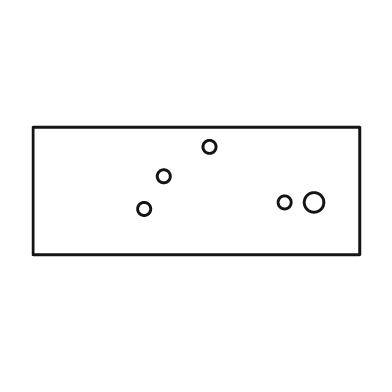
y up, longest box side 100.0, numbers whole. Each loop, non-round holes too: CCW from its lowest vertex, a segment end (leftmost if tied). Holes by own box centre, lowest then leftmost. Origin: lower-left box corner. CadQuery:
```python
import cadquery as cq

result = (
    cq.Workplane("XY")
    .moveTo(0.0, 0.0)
    .lineTo(100.0, 0.0)
    .lineTo(100.0, 39.0)
    .lineTo(0.0, 39.0)
    .close()
    .moveTo(34.0, 14.0)
    .circle(2.0)
    .moveTo(77.0, 16.0)
    .circle(2.0)
    .moveTo(86.0, 16.0)
    .circle(3.0)
    .moveTo(40.0, 24.0)
    .circle(2.0)
    .moveTo(54.0, 33.0)
    .circle(2.0)
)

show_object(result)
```